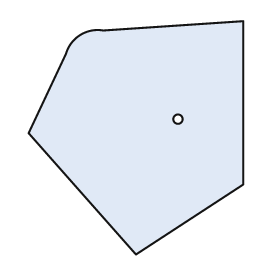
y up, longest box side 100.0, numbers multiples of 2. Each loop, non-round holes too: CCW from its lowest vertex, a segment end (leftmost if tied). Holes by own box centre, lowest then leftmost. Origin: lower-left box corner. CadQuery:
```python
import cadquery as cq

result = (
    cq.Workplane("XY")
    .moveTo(46.0, 0.0)
    .lineTo(92.0, 30.0)
    .lineTo(92.0, 100.0)
    .lineTo(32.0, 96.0)
    .threePointArc((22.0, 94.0), (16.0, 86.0))
    .lineTo(0.0, 52.0)
    .close()
    .moveTo(64.0, 58.0)
    .circle(2.0)
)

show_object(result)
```